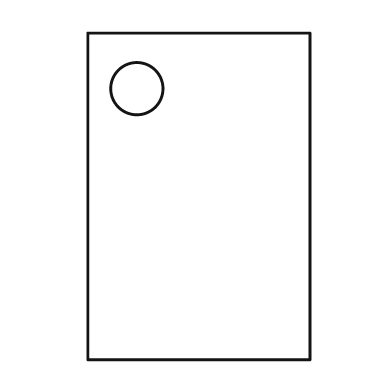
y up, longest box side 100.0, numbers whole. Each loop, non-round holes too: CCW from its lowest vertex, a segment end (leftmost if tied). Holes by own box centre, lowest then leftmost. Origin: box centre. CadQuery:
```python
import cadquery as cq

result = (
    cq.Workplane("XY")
    .moveTo(-34.0, -50.0)
    .lineTo(34.0, -50.0)
    .lineTo(34.0, 50.0)
    .lineTo(-34.0, 50.0)
    .close()
    .moveTo(-19.0, 33.0)
    .circle(8.0)
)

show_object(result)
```